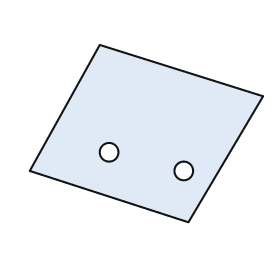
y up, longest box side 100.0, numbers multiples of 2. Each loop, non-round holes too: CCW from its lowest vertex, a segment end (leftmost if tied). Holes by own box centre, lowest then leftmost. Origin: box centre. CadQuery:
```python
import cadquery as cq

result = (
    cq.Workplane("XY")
    .moveTo(18.0, -38.0)
    .lineTo(50.0, 16.0)
    .lineTo(-20.0, 38.0)
    .lineTo(-50.0, -16.0)
    .close()
    .moveTo(16.0, -16.0)
    .circle(4.0)
    .moveTo(-16.0, -8.0)
    .circle(4.0)
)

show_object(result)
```